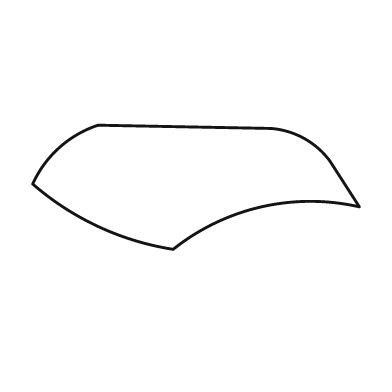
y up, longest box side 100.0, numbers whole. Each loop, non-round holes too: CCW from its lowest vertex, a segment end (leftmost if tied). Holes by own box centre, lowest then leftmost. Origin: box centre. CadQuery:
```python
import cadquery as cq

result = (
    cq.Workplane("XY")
    .moveTo(-7.0, -19.0)
    .threePointArc((20.0, -6.0), (50.0, -6.0))
    .lineTo(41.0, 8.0)
    .threePointArc((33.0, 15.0), (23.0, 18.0))
    .lineTo(-30.0, 19.0)
    .threePointArc((-42.0, 12.0), (-50.0, 1.0))
    .threePointArc((-30.0, -12.0), (-7.0, -19.0))
    .close()
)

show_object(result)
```